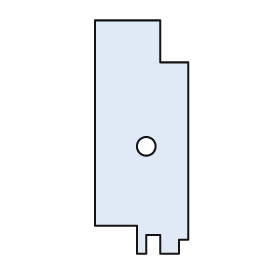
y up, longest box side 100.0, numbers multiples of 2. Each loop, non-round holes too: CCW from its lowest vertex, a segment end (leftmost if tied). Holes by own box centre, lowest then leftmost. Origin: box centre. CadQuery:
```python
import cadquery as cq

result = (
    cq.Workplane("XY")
    .moveTo(-2.0, -50.0)
    .lineTo(2.0, -50.0)
    .lineTo(2.0, -42.0)
    .lineTo(8.0, -42.0)
    .lineTo(8.0, -50.0)
    .lineTo(16.0, -50.0)
    .lineTo(16.0, -44.0)
    .lineTo(20.0, -44.0)
    .lineTo(20.0, 32.0)
    .lineTo(8.0, 32.0)
    .lineTo(8.0, 50.0)
    .lineTo(-20.0, 50.0)
    .lineTo(-20.0, -38.0)
    .lineTo(-2.0, -38.0)
    .close()
    .moveTo(2.0, -4.0)
    .circle(4.0)
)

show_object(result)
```